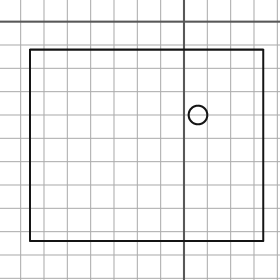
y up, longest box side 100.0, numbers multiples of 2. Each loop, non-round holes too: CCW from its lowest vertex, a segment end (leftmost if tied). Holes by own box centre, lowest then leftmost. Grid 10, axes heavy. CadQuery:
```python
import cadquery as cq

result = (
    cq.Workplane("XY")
    .moveTo(-66.0, -94.0)
    .lineTo(34.0, -94.0)
    .lineTo(34.0, -12.0)
    .lineTo(-66.0, -12.0)
    .close()
    .moveTo(6.0, -40.0)
    .circle(4.0)
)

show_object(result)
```